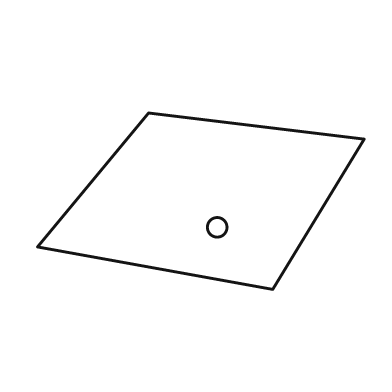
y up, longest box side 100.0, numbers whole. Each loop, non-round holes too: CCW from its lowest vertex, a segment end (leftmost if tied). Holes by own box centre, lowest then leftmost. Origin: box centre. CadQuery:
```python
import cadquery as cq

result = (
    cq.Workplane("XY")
    .moveTo(22.0, -27.0)
    .lineTo(50.0, 19.0)
    .lineTo(-16.0, 27.0)
    .lineTo(-50.0, -14.0)
    .close()
    .moveTo(5.0, -8.0)
    .circle(3.0)
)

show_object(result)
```